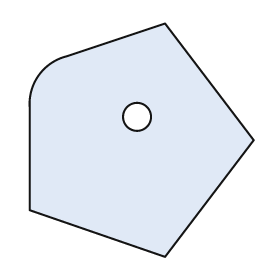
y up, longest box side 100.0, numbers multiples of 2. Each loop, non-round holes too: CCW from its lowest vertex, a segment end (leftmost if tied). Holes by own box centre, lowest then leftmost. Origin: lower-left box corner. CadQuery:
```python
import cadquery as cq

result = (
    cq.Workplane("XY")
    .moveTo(58.0, 0.0)
    .lineTo(96.0, 50.0)
    .lineTo(58.0, 100.0)
    .lineTo(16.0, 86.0)
    .threePointArc((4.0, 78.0), (0.0, 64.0))
    .lineTo(0.0, 20.0)
    .close()
    .moveTo(46.0, 60.0)
    .circle(6.0)
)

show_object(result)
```